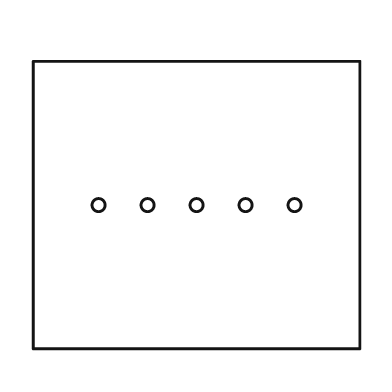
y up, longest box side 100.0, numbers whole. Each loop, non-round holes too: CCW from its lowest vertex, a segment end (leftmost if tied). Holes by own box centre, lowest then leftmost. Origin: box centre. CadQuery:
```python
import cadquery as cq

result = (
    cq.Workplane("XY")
    .moveTo(-50.0, -44.0)
    .lineTo(50.0, -44.0)
    .lineTo(50.0, 44.0)
    .lineTo(-50.0, 44.0)
    .close()
    .moveTo(-30.0, 0.0)
    .circle(2.0)
    .moveTo(-15.0, 0.0)
    .circle(2.0)
    .moveTo(0.0, 0.0)
    .circle(2.0)
    .moveTo(15.0, 0.0)
    .circle(2.0)
    .moveTo(30.0, 0.0)
    .circle(2.0)
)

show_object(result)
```